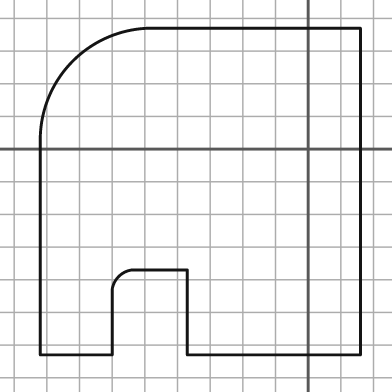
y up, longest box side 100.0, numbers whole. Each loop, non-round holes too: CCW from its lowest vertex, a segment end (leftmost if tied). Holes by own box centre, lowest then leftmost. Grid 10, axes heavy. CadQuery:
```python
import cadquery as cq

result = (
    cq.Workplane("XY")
    .moveTo(-82.0, -63.0)
    .lineTo(-60.0, -63.0)
    .lineTo(-60.0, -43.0)
    .threePointArc((-58.0, -39.0), (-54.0, -37.0))
    .lineTo(-37.0, -37.0)
    .lineTo(-37.0, -63.0)
    .lineTo(16.0, -63.0)
    .lineTo(16.0, 37.0)
    .lineTo(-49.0, 37.0)
    .threePointArc((-72.0, 27.0), (-82.0, 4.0))
    .close()
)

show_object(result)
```